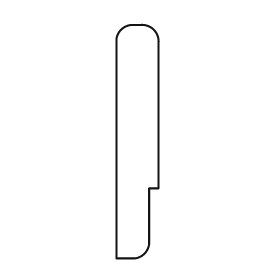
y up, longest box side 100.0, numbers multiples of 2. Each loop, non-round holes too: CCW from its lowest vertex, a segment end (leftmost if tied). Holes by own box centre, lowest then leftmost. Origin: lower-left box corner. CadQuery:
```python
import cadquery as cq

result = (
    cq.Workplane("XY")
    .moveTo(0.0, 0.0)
    .lineTo(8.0, 0.0)
    .threePointArc((12.0, 2.0), (14.0, 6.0))
    .lineTo(14.0, 30.0)
    .lineTo(18.0, 30.0)
    .lineTo(18.0, 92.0)
    .threePointArc((16.0, 98.0), (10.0, 100.0))
    .lineTo(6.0, 100.0)
    .threePointArc((2.0, 98.0), (0.0, 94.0))
    .close()
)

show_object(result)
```